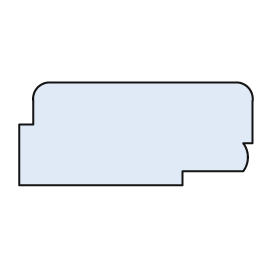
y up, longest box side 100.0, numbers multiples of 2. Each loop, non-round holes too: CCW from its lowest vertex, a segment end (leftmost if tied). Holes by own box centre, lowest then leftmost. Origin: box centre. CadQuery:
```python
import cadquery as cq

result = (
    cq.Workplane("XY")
    .moveTo(-50.0, -22.0)
    .lineTo(20.0, -22.0)
    .lineTo(20.0, -16.0)
    .lineTo(46.0, -16.0)
    .threePointArc((48.0, -10.0), (46.0, -4.0))
    .lineTo(50.0, -4.0)
    .lineTo(50.0, 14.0)
    .threePointArc((48.0, 20.0), (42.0, 22.0))
    .lineTo(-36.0, 22.0)
    .threePointArc((-42.0, 20.0), (-44.0, 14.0))
    .lineTo(-44.0, 4.0)
    .lineTo(-50.0, 4.0)
    .close()
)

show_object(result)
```